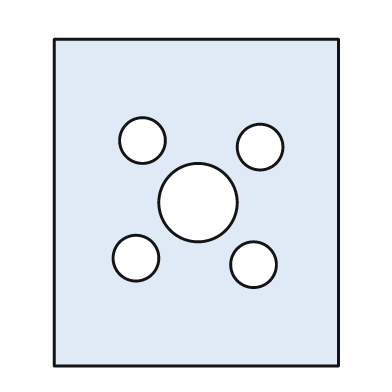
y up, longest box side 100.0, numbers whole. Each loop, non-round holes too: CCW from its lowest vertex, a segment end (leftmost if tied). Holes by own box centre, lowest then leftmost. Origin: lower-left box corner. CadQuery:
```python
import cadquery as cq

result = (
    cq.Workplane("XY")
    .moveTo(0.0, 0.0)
    .lineTo(87.0, 0.0)
    .lineTo(87.0, 100.0)
    .lineTo(0.0, 100.0)
    .close()
    .moveTo(61.0, 31.0)
    .circle(7.0)
    .moveTo(25.0, 33.0)
    .circle(7.0)
    .moveTo(44.0, 50.0)
    .circle(12.0)
    .moveTo(63.0, 67.0)
    .circle(7.0)
    .moveTo(27.0, 69.0)
    .circle(7.0)
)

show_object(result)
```